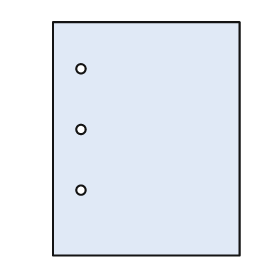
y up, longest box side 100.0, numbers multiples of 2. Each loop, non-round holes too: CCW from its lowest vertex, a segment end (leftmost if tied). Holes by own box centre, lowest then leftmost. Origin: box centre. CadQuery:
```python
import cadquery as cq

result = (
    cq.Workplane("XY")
    .moveTo(-40.0, -50.0)
    .lineTo(40.0, -50.0)
    .lineTo(40.0, 50.0)
    .lineTo(-40.0, 50.0)
    .close()
    .moveTo(-28.0, -22.0)
    .circle(2.0)
    .moveTo(-28.0, 4.0)
    .circle(2.0)
    .moveTo(-28.0, 30.0)
    .circle(2.0)
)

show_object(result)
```